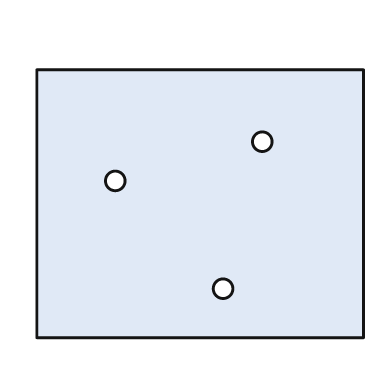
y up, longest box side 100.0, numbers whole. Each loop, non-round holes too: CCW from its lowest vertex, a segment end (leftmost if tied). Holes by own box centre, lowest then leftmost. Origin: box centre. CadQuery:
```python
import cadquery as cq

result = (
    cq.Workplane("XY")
    .moveTo(-50.0, -41.0)
    .lineTo(50.0, -41.0)
    .lineTo(50.0, 41.0)
    .lineTo(-50.0, 41.0)
    .close()
    .moveTo(7.0, -26.0)
    .circle(3.0)
    .moveTo(-26.0, 7.0)
    .circle(3.0)
    .moveTo(19.0, 19.0)
    .circle(3.0)
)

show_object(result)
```